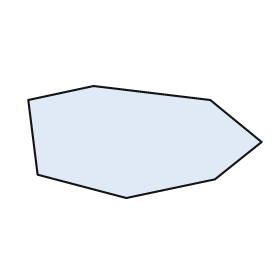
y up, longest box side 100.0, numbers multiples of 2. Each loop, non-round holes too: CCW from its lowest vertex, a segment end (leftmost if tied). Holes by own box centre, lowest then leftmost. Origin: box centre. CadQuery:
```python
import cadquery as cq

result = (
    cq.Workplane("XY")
    .moveTo(-8.0, -24.0)
    .lineTo(30.0, -16.0)
    .lineTo(50.0, 0.0)
    .lineTo(28.0, 18.0)
    .lineTo(-22.0, 24.0)
    .lineTo(-50.0, 18.0)
    .lineTo(-46.0, -14.0)
    .close()
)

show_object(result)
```